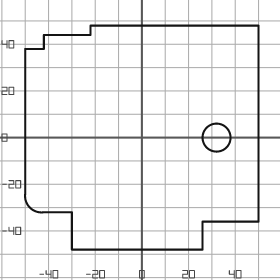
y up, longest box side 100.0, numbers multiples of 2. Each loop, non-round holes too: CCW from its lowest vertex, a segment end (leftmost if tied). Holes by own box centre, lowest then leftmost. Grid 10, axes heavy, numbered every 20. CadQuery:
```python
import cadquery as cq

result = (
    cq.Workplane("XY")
    .moveTo(-30.0, -48.0)
    .lineTo(26.0, -48.0)
    .lineTo(26.0, -36.0)
    .lineTo(50.0, -36.0)
    .lineTo(50.0, 48.0)
    .lineTo(-22.0, 48.0)
    .lineTo(-22.0, 44.0)
    .lineTo(-42.0, 44.0)
    .lineTo(-42.0, 38.0)
    .lineTo(-50.0, 38.0)
    .lineTo(-50.0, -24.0)
    .threePointArc((-48.0, -30.0), (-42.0, -32.0))
    .lineTo(-30.0, -32.0)
    .close()
    .moveTo(32.0, 0.0)
    .circle(6.0)
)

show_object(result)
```